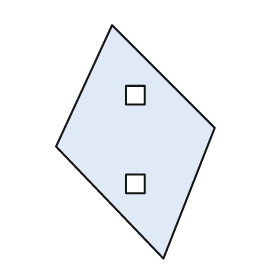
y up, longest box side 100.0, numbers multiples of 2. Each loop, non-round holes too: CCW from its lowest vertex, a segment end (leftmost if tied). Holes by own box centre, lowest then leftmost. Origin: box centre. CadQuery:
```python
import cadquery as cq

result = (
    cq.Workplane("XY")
    .moveTo(12.0, -50.0)
    .lineTo(34.0, 6.0)
    .lineTo(-10.0, 50.0)
    .lineTo(-34.0, -2.0)
    .close()
    .moveTo(-4.0, -22.0)
    .lineTo(4.0, -22.0)
    .lineTo(4.0, -14.0)
    .lineTo(-4.0, -14.0)
    .close()
    .moveTo(-4.0, 16.0)
    .lineTo(4.0, 16.0)
    .lineTo(4.0, 24.0)
    .lineTo(-4.0, 24.0)
    .close()
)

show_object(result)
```